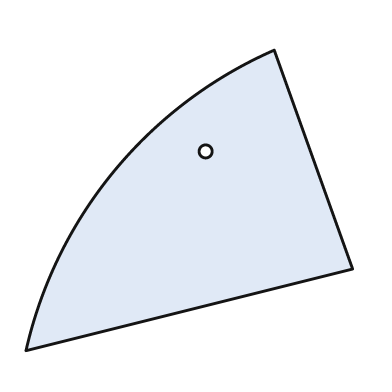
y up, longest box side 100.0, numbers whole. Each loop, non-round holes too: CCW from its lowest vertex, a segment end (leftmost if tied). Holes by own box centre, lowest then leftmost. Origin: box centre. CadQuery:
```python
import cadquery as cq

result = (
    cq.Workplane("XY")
    .moveTo(-50.0, -46.0)
    .lineTo(50.0, -21.0)
    .lineTo(26.0, 46.0)
    .threePointArc((-23.0, 9.0), (-50.0, -46.0))
    .close()
    .moveTo(5.0, 15.0)
    .circle(2.0)
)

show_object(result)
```